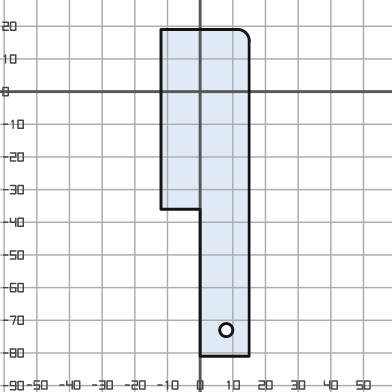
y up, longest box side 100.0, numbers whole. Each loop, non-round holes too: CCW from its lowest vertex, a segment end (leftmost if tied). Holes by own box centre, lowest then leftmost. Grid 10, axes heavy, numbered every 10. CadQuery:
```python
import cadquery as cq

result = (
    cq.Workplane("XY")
    .moveTo(0.0, -81.0)
    .lineTo(15.0, -81.0)
    .lineTo(15.0, 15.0)
    .threePointArc((14.0, 18.0), (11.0, 19.0))
    .lineTo(-12.0, 19.0)
    .lineTo(-12.0, -36.0)
    .lineTo(0.0, -36.0)
    .close()
    .moveTo(8.0, -73.0)
    .circle(2.0)
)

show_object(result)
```